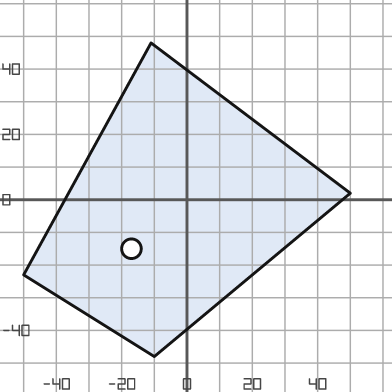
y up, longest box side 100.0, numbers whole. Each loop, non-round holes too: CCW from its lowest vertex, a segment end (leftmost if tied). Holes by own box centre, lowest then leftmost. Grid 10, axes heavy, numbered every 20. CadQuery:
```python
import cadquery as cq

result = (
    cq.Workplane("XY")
    .moveTo(-10.0, -48.0)
    .lineTo(50.0, 2.0)
    .lineTo(-11.0, 48.0)
    .lineTo(-50.0, -23.0)
    .close()
    .moveTo(-17.0, -15.0)
    .circle(3.0)
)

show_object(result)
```